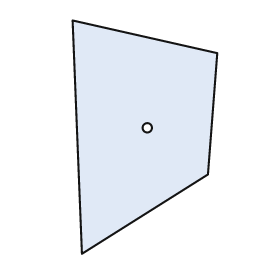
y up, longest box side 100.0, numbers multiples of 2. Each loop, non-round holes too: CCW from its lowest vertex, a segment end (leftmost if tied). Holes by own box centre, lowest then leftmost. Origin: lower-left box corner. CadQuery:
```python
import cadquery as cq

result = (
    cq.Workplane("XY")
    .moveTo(4.0, 0.0)
    .lineTo(58.0, 34.0)
    .lineTo(62.0, 86.0)
    .lineTo(0.0, 100.0)
    .close()
    .moveTo(32.0, 54.0)
    .circle(2.0)
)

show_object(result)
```